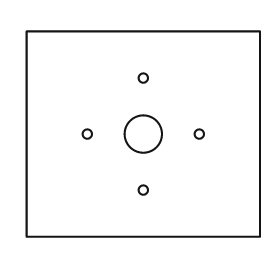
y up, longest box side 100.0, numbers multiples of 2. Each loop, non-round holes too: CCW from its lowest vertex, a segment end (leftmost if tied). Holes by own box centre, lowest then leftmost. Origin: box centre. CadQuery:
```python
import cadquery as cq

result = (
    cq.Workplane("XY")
    .moveTo(-50.0, -44.0)
    .lineTo(50.0, -44.0)
    .lineTo(50.0, 44.0)
    .lineTo(-50.0, 44.0)
    .close()
    .moveTo(0.0, -24.0)
    .circle(2.0)
    .moveTo(-24.0, 0.0)
    .circle(2.0)
    .moveTo(0.0, 0.0)
    .circle(8.0)
    .moveTo(24.0, 0.0)
    .circle(2.0)
    .moveTo(0.0, 24.0)
    .circle(2.0)
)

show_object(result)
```